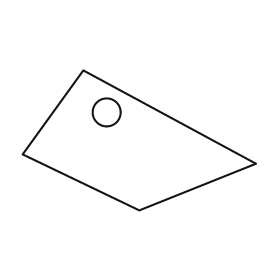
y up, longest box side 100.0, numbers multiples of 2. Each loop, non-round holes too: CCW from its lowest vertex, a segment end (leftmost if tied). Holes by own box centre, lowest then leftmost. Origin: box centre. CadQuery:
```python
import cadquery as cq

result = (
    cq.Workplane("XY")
    .moveTo(0.0, -30.0)
    .lineTo(50.0, -10.0)
    .lineTo(-24.0, 30.0)
    .lineTo(-50.0, -6.0)
    .close()
    .moveTo(-14.0, 12.0)
    .circle(6.0)
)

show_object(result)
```